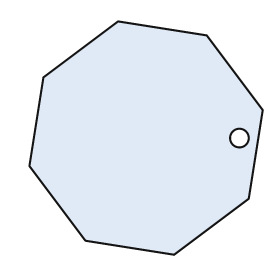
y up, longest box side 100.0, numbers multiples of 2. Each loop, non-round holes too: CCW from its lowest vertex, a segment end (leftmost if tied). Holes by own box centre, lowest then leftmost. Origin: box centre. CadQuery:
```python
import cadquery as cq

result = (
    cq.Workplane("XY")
    .moveTo(12.0, -50.0)
    .lineTo(44.0, -26.0)
    .lineTo(50.0, 12.0)
    .lineTo(26.0, 44.0)
    .lineTo(-12.0, 50.0)
    .lineTo(-44.0, 26.0)
    .lineTo(-50.0, -12.0)
    .lineTo(-26.0, -44.0)
    .close()
    .moveTo(40.0, 0.0)
    .circle(4.0)
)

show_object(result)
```